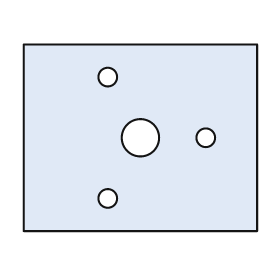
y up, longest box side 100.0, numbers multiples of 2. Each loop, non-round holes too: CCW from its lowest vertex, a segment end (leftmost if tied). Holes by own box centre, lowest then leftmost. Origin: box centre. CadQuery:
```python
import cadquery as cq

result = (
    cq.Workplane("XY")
    .moveTo(-50.0, -40.0)
    .lineTo(50.0, -40.0)
    .lineTo(50.0, 40.0)
    .lineTo(-50.0, 40.0)
    .close()
    .moveTo(-14.0, -26.0)
    .circle(4.0)
    .moveTo(0.0, 0.0)
    .circle(8.0)
    .moveTo(28.0, 0.0)
    .circle(4.0)
    .moveTo(-14.0, 26.0)
    .circle(4.0)
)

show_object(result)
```